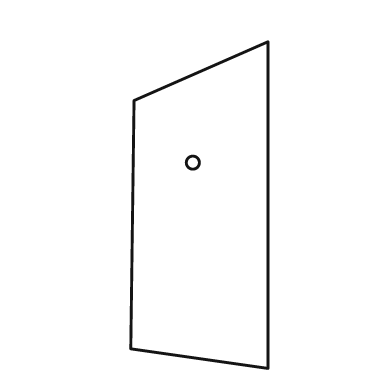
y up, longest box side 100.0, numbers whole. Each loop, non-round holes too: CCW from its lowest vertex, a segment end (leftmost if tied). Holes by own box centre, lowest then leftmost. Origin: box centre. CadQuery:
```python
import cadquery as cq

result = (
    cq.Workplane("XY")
    .moveTo(21.0, -50.0)
    .lineTo(21.0, 50.0)
    .lineTo(-20.0, 32.0)
    .lineTo(-21.0, -44.0)
    .close()
    .moveTo(-2.0, 13.0)
    .circle(2.0)
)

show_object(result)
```